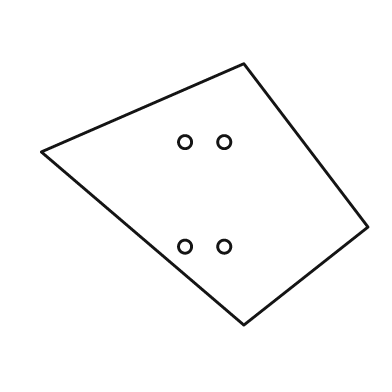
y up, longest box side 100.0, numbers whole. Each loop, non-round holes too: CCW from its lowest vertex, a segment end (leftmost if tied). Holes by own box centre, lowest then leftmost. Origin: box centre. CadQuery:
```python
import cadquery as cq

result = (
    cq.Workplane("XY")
    .moveTo(12.0, -40.0)
    .lineTo(50.0, -10.0)
    .lineTo(12.0, 40.0)
    .lineTo(-50.0, 13.0)
    .close()
    .moveTo(-6.0, -16.0)
    .circle(2.0)
    .moveTo(6.0, -16.0)
    .circle(2.0)
    .moveTo(-6.0, 16.0)
    .circle(2.0)
    .moveTo(6.0, 16.0)
    .circle(2.0)
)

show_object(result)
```